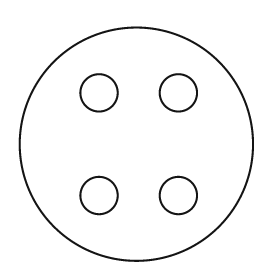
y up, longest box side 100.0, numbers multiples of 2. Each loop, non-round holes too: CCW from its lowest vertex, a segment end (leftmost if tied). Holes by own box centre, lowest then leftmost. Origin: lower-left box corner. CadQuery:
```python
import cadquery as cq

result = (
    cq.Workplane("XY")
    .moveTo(50.0, 50.0)
    .circle(50.0)
    .moveTo(34.0, 28.0)
    .circle(8.0)
    .moveTo(68.0, 28.0)
    .circle(8.0)
    .moveTo(34.0, 72.0)
    .circle(8.0)
    .moveTo(68.0, 72.0)
    .circle(8.0)
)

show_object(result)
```